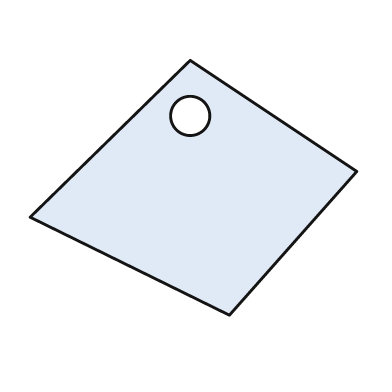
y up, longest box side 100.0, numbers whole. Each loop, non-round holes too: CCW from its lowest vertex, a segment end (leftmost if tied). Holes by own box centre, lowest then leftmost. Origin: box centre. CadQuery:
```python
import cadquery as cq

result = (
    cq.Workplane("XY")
    .moveTo(11.0, -39.0)
    .lineTo(50.0, 5.0)
    .lineTo(-1.0, 39.0)
    .lineTo(-50.0, -9.0)
    .close()
    .moveTo(-1.0, 22.0)
    .circle(6.0)
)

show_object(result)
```